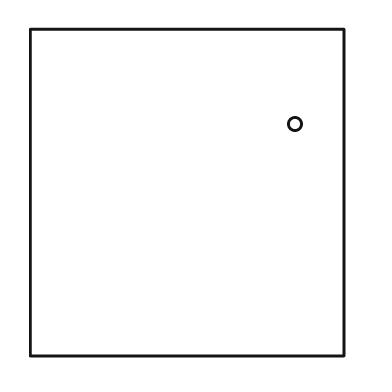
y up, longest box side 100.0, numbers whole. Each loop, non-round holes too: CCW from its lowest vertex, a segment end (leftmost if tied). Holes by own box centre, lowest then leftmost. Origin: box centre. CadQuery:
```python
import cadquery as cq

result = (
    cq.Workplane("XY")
    .moveTo(-48.0, -50.0)
    .lineTo(48.0, -50.0)
    .lineTo(48.0, 50.0)
    .lineTo(-48.0, 50.0)
    .close()
    .moveTo(33.0, 21.0)
    .circle(2.0)
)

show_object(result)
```